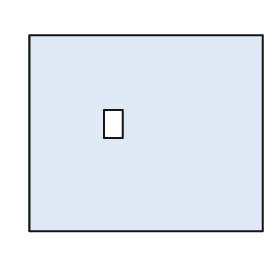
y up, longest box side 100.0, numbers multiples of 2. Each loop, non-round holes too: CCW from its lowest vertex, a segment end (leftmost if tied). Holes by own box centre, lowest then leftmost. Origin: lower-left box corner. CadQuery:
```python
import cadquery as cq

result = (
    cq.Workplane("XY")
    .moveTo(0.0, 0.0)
    .lineTo(100.0, 0.0)
    .lineTo(100.0, 84.0)
    .lineTo(0.0, 84.0)
    .close()
    .moveTo(32.0, 40.0)
    .lineTo(40.0, 40.0)
    .lineTo(40.0, 52.0)
    .lineTo(32.0, 52.0)
    .close()
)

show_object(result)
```